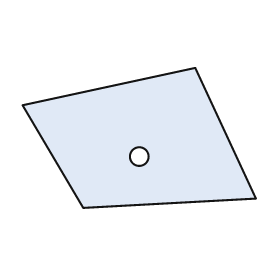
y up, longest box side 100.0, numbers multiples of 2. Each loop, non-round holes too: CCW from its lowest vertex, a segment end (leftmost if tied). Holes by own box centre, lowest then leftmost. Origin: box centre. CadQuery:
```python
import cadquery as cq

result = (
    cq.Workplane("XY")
    .moveTo(-24.0, -30.0)
    .lineTo(50.0, -26.0)
    .lineTo(24.0, 30.0)
    .lineTo(-50.0, 14.0)
    .close()
    .moveTo(0.0, -8.0)
    .circle(4.0)
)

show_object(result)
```